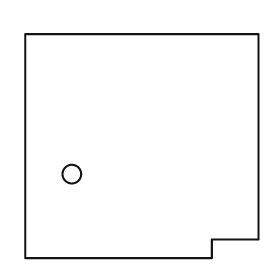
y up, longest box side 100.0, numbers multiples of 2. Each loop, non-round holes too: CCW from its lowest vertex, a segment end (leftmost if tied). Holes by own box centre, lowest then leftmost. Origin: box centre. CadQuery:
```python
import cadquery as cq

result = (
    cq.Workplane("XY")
    .moveTo(-50.0, -48.0)
    .lineTo(30.0, -48.0)
    .lineTo(30.0, -40.0)
    .lineTo(50.0, -40.0)
    .lineTo(50.0, 48.0)
    .lineTo(-50.0, 48.0)
    .close()
    .moveTo(-30.0, -12.0)
    .circle(4.0)
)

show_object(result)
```